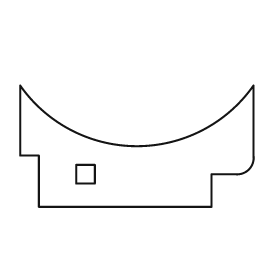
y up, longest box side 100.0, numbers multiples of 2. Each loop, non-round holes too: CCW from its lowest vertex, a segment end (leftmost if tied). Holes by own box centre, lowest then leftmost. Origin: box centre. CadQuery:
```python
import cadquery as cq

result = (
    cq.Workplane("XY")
    .moveTo(-42.0, -26.0)
    .lineTo(32.0, -26.0)
    .lineTo(32.0, -12.0)
    .lineTo(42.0, -12.0)
    .threePointArc((48.0, -10.0), (50.0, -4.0))
    .lineTo(50.0, 26.0)
    .threePointArc((0.0, 0.0), (-50.0, 26.0))
    .lineTo(-50.0, -4.0)
    .lineTo(-42.0, -4.0)
    .close()
    .moveTo(-26.0, -16.0)
    .lineTo(-18.0, -16.0)
    .lineTo(-18.0, -8.0)
    .lineTo(-26.0, -8.0)
    .close()
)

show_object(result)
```